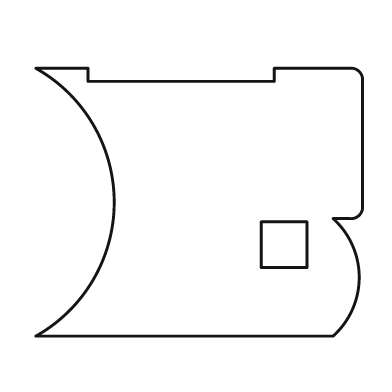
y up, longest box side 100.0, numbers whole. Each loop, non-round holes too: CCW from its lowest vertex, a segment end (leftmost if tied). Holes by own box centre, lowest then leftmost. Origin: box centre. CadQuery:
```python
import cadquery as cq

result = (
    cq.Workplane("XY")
    .moveTo(-50.0, -41.0)
    .lineTo(41.0, -41.0)
    .threePointArc((49.0, -23.0), (41.0, -5.0))
    .lineTo(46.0, -5.0)
    .threePointArc((49.0, -4.0), (50.0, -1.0))
    .lineTo(50.0, 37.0)
    .threePointArc((49.0, 40.0), (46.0, 41.0))
    .lineTo(23.0, 41.0)
    .lineTo(23.0, 37.0)
    .lineTo(-34.0, 37.0)
    .lineTo(-34.0, 41.0)
    .lineTo(-50.0, 41.0)
    .threePointArc((-26.0, 0.0), (-50.0, -41.0))
    .close()
    .moveTo(19.0, -20.0)
    .lineTo(33.0, -20.0)
    .lineTo(33.0, -6.0)
    .lineTo(19.0, -6.0)
    .close()
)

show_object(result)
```